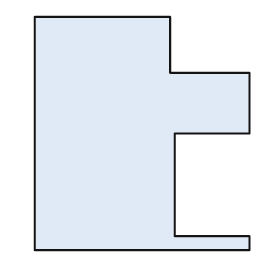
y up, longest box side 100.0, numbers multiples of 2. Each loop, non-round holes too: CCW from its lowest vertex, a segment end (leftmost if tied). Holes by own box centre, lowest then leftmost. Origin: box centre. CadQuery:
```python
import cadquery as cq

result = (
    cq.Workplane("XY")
    .moveTo(-46.0, -50.0)
    .lineTo(46.0, -50.0)
    .lineTo(46.0, -44.0)
    .lineTo(14.0, -44.0)
    .lineTo(14.0, 0.0)
    .lineTo(46.0, 0.0)
    .lineTo(46.0, 26.0)
    .lineTo(12.0, 26.0)
    .lineTo(12.0, 50.0)
    .lineTo(-46.0, 50.0)
    .close()
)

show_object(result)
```